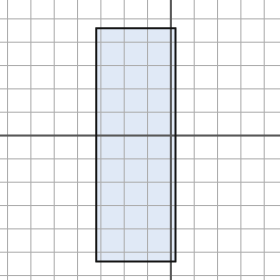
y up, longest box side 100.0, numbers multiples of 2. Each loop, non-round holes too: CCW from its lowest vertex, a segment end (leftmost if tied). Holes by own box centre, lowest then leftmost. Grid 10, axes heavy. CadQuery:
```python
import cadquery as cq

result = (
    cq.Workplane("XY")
    .moveTo(-32.0, -54.0)
    .lineTo(2.0, -54.0)
    .lineTo(2.0, 46.0)
    .lineTo(-32.0, 46.0)
    .close()
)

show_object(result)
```